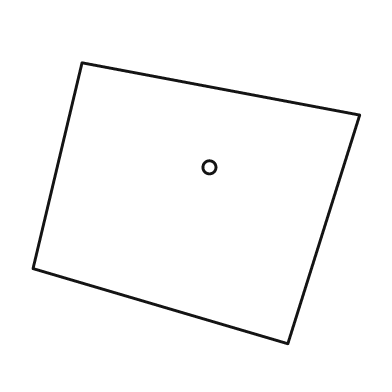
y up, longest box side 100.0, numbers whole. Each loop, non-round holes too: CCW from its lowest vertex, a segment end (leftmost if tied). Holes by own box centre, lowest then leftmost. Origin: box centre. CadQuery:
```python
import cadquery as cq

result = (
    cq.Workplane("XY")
    .moveTo(28.0, -43.0)
    .lineTo(50.0, 27.0)
    .lineTo(-35.0, 43.0)
    .lineTo(-50.0, -20.0)
    .close()
    .moveTo(4.0, 11.0)
    .circle(2.0)
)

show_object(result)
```